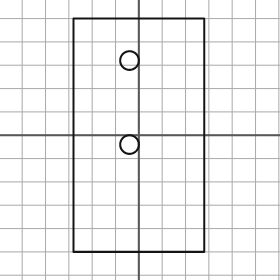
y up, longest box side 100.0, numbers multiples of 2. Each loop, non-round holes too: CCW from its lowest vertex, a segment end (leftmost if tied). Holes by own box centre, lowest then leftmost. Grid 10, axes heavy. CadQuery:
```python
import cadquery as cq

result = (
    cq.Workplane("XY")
    .moveTo(-28.0, -50.0)
    .lineTo(28.0, -50.0)
    .lineTo(28.0, 50.0)
    .lineTo(-28.0, 50.0)
    .close()
    .moveTo(-4.0, -4.0)
    .circle(4.0)
    .moveTo(-4.0, 32.0)
    .circle(4.0)
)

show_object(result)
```